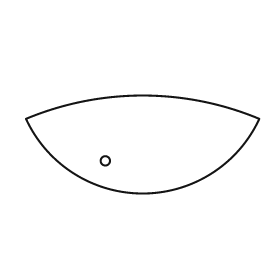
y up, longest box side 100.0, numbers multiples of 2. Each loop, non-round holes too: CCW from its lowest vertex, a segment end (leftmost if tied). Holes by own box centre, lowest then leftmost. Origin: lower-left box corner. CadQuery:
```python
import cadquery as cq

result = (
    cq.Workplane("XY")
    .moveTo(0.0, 32.0)
    .threePointArc((50.0, 0.0), (100.0, 32.0))
    .threePointArc((50.0, 42.0), (0.0, 32.0))
    .close()
    .moveTo(34.0, 14.0)
    .circle(2.0)
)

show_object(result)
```